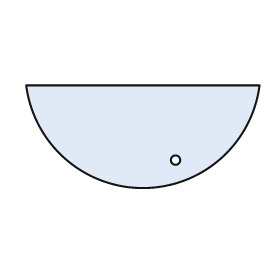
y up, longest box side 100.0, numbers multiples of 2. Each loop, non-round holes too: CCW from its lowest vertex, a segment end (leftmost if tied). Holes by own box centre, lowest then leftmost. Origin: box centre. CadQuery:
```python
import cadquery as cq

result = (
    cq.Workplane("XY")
    .moveTo(-50.0, 22.0)
    .threePointArc((0.0, -22.0), (50.0, 22.0))
    .close()
    .moveTo(14.0, -10.0)
    .circle(2.0)
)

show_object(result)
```